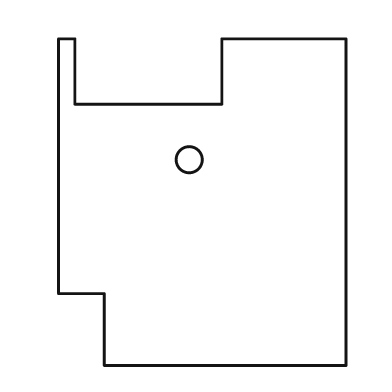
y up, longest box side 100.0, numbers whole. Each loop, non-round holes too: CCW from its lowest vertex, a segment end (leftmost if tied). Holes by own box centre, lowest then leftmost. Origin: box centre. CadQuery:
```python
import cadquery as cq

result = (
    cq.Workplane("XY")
    .moveTo(-30.0, -50.0)
    .lineTo(44.0, -50.0)
    .lineTo(44.0, 50.0)
    .lineTo(6.0, 50.0)
    .lineTo(6.0, 30.0)
    .lineTo(-39.0, 30.0)
    .lineTo(-39.0, 50.0)
    .lineTo(-44.0, 50.0)
    .lineTo(-44.0, -28.0)
    .lineTo(-30.0, -28.0)
    .close()
    .moveTo(-4.0, 13.0)
    .circle(4.0)
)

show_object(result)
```